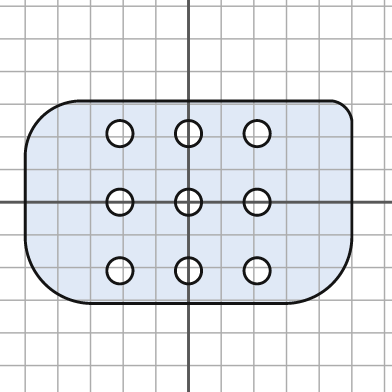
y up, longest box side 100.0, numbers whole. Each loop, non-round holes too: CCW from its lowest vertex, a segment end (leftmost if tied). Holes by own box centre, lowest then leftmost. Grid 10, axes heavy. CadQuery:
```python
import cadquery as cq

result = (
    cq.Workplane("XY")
    .moveTo(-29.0, -31.0)
    .lineTo(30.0, -31.0)
    .threePointArc((44.0, -25.0), (50.0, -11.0))
    .lineTo(50.0, 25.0)
    .threePointArc((48.0, 29.0), (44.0, 31.0))
    .lineTo(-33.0, 31.0)
    .threePointArc((-45.0, 26.0), (-50.0, 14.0))
    .lineTo(-50.0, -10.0)
    .threePointArc((-44.0, -25.0), (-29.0, -31.0))
    .close()
    .moveTo(-21.0, -21.0)
    .circle(4.0)
    .moveTo(0.0, -21.0)
    .circle(4.0)
    .moveTo(21.0, -21.0)
    .circle(4.0)
    .moveTo(-21.0, 0.0)
    .circle(4.0)
    .moveTo(0.0, 0.0)
    .circle(4.0)
    .moveTo(21.0, 0.0)
    .circle(4.0)
    .moveTo(-21.0, 21.0)
    .circle(4.0)
    .moveTo(0.0, 21.0)
    .circle(4.0)
    .moveTo(21.0, 21.0)
    .circle(4.0)
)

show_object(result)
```